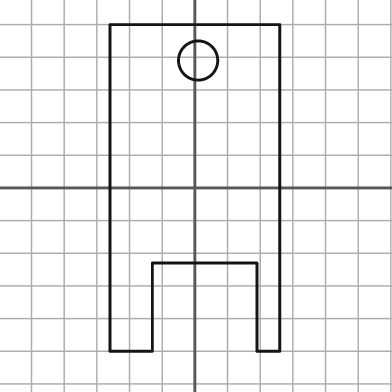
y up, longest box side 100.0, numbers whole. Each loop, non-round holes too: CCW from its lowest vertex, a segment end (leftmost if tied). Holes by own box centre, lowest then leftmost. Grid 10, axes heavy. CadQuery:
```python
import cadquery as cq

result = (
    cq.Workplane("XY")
    .moveTo(-26.0, -50.0)
    .lineTo(-13.0, -50.0)
    .lineTo(-13.0, -23.0)
    .lineTo(19.0, -23.0)
    .lineTo(19.0, -50.0)
    .lineTo(26.0, -50.0)
    .lineTo(26.0, 50.0)
    .lineTo(-26.0, 50.0)
    .close()
    .moveTo(1.0, 39.0)
    .circle(6.0)
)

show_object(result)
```